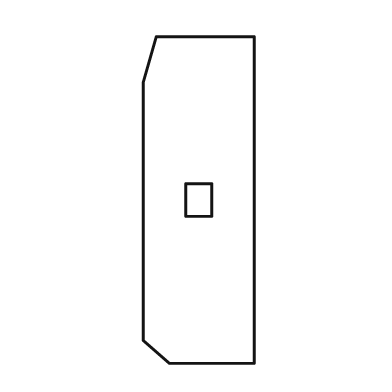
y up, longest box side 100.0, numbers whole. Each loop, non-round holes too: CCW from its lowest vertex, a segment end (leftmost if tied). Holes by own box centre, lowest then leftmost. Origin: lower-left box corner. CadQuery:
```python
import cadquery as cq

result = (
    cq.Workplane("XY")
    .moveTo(8.0, 0.0)
    .lineTo(34.0, 0.0)
    .lineTo(34.0, 100.0)
    .lineTo(4.0, 100.0)
    .lineTo(0.0, 86.0)
    .lineTo(0.0, 7.0)
    .close()
    .moveTo(13.0, 45.0)
    .lineTo(21.0, 45.0)
    .lineTo(21.0, 55.0)
    .lineTo(13.0, 55.0)
    .close()
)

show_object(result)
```